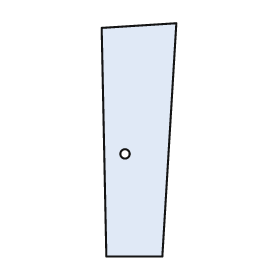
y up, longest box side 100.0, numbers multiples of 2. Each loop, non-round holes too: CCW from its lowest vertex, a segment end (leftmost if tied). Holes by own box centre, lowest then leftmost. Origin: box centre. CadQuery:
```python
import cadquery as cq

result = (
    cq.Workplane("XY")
    .moveTo(-14.0, -50.0)
    .lineTo(10.0, -50.0)
    .lineTo(16.0, 50.0)
    .lineTo(-16.0, 48.0)
    .close()
    .moveTo(-6.0, -6.0)
    .circle(2.0)
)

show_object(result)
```